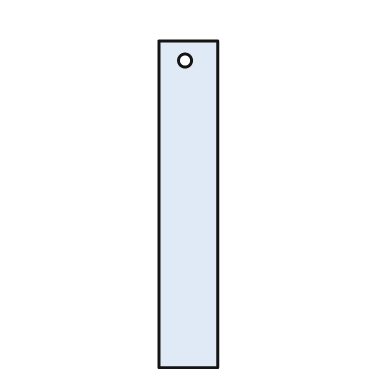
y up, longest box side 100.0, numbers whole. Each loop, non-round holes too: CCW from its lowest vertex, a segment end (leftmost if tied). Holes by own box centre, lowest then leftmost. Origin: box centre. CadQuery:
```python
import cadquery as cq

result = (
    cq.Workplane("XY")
    .moveTo(-9.0, -50.0)
    .lineTo(9.0, -50.0)
    .lineTo(9.0, 50.0)
    .lineTo(-9.0, 50.0)
    .close()
    .moveTo(-1.0, 44.0)
    .circle(2.0)
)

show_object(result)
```